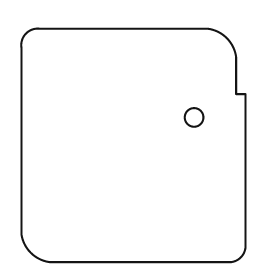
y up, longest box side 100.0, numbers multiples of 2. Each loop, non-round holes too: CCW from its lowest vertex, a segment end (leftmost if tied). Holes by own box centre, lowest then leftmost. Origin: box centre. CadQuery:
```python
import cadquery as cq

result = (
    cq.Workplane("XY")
    .moveTo(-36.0, -50.0)
    .lineTo(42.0, -50.0)
    .threePointArc((46.0, -48.0), (48.0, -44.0))
    .lineTo(48.0, 22.0)
    .lineTo(44.0, 22.0)
    .lineTo(44.0, 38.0)
    .threePointArc((40.0, 46.0), (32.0, 50.0))
    .lineTo(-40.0, 50.0)
    .threePointArc((-46.0, 48.0), (-48.0, 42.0))
    .lineTo(-48.0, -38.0)
    .threePointArc((-44.0, -46.0), (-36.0, -50.0))
    .close()
    .moveTo(26.0, 12.0)
    .circle(4.0)
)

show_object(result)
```